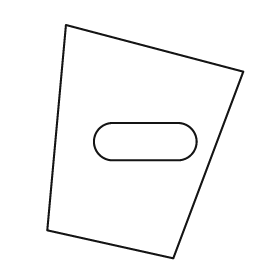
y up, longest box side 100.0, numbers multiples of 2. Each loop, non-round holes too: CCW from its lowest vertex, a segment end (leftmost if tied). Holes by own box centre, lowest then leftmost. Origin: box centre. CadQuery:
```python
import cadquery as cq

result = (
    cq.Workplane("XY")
    .moveTo(12.0, -50.0)
    .lineTo(42.0, 30.0)
    .lineTo(-34.0, 50.0)
    .lineTo(-42.0, -38.0)
    .close()
    .moveTo(-14.0, -8.0)
    .lineTo(14.0, -8.0)
    .threePointArc((22.0, 0.0), (14.0, 8.0))
    .lineTo(-14.0, 8.0)
    .threePointArc((-22.0, 0.0), (-14.0, -8.0))
    .close()
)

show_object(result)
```